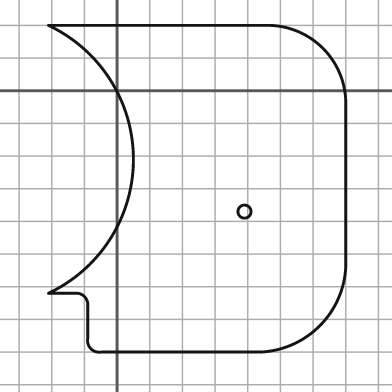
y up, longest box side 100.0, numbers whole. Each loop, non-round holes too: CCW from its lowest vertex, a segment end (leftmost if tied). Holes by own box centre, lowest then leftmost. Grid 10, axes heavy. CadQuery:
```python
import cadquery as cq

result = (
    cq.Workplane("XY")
    .moveTo(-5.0, -80.0)
    .lineTo(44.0, -80.0)
    .threePointArc((62.0, -72.0), (70.0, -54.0))
    .lineTo(70.0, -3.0)
    .threePointArc((63.0, 13.0), (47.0, 20.0))
    .lineTo(-21.0, 20.0)
    .threePointArc((5.0, -21.0), (-21.0, -62.0))
    .lineTo(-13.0, -62.0)
    .threePointArc((-10.0, -63.0), (-9.0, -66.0))
    .lineTo(-9.0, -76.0)
    .threePointArc((-8.0, -79.0), (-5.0, -80.0))
    .close()
    .moveTo(39.0, -37.0)
    .circle(2.0)
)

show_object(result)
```